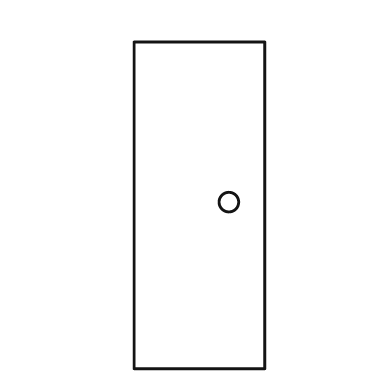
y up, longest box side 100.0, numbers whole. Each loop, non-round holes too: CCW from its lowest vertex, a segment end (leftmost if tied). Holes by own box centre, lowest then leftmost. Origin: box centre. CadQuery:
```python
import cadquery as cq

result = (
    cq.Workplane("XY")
    .moveTo(-20.0, -50.0)
    .lineTo(20.0, -50.0)
    .lineTo(20.0, 50.0)
    .lineTo(-20.0, 50.0)
    .close()
    .moveTo(9.0, 1.0)
    .circle(3.0)
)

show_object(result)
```